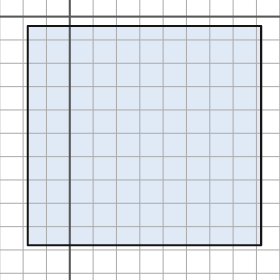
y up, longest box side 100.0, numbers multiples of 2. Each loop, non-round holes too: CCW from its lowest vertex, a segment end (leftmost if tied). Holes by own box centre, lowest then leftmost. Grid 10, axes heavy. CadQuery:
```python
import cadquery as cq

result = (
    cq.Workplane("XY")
    .moveTo(-18.0, -98.0)
    .lineTo(82.0, -98.0)
    .lineTo(82.0, -4.0)
    .lineTo(-18.0, -4.0)
    .close()
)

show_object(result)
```